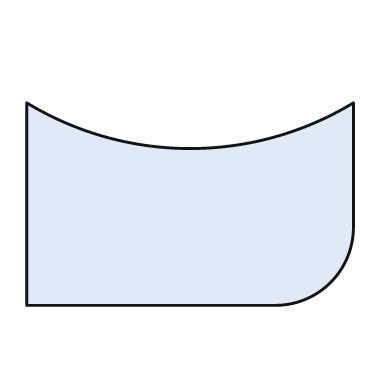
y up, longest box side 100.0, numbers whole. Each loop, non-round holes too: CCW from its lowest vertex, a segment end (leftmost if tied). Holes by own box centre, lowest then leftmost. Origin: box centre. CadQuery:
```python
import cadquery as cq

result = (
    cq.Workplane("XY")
    .moveTo(-50.0, -31.0)
    .lineTo(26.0, -31.0)
    .threePointArc((43.0, -24.0), (50.0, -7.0))
    .lineTo(50.0, 31.0)
    .threePointArc((0.0, 17.0), (-50.0, 31.0))
    .close()
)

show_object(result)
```